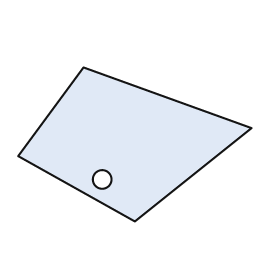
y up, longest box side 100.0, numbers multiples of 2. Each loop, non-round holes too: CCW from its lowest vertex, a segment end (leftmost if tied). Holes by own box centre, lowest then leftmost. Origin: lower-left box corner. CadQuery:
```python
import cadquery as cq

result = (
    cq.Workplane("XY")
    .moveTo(50.0, 0.0)
    .lineTo(100.0, 40.0)
    .lineTo(28.0, 66.0)
    .lineTo(0.0, 28.0)
    .close()
    .moveTo(36.0, 18.0)
    .circle(4.0)
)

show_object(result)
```